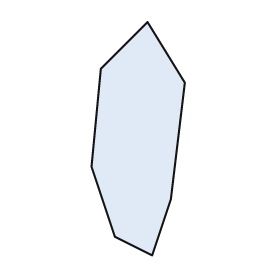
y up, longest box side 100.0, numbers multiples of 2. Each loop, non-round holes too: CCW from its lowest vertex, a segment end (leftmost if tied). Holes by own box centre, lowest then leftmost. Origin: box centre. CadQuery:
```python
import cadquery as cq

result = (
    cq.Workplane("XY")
    .moveTo(6.0, -50.0)
    .lineTo(14.0, -26.0)
    .lineTo(20.0, 24.0)
    .lineTo(4.0, 50.0)
    .lineTo(-16.0, 30.0)
    .lineTo(-20.0, -12.0)
    .lineTo(-10.0, -42.0)
    .close()
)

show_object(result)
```